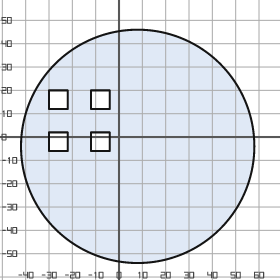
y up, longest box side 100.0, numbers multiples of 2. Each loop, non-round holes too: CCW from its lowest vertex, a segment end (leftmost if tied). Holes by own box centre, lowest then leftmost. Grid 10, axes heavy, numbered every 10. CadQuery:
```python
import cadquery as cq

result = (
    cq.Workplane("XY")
    .moveTo(8.0, -4.0)
    .circle(50.0)
    .moveTo(-30.0, -6.0)
    .lineTo(-22.0, -6.0)
    .lineTo(-22.0, 2.0)
    .lineTo(-30.0, 2.0)
    .close()
    .moveTo(-12.0, -6.0)
    .lineTo(-4.0, -6.0)
    .lineTo(-4.0, 2.0)
    .lineTo(-12.0, 2.0)
    .close()
    .moveTo(-30.0, 12.0)
    .lineTo(-22.0, 12.0)
    .lineTo(-22.0, 20.0)
    .lineTo(-30.0, 20.0)
    .close()
    .moveTo(-12.0, 12.0)
    .lineTo(-4.0, 12.0)
    .lineTo(-4.0, 20.0)
    .lineTo(-12.0, 20.0)
    .close()
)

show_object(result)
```